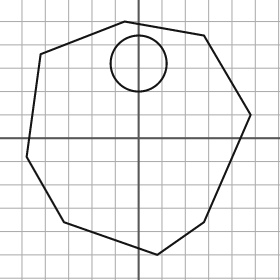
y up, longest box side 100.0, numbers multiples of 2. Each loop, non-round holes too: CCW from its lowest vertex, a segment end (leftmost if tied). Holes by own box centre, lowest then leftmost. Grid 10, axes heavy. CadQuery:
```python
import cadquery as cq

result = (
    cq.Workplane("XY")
    .moveTo(8.0, -50.0)
    .lineTo(28.0, -36.0)
    .lineTo(48.0, 10.0)
    .lineTo(28.0, 44.0)
    .lineTo(-6.0, 50.0)
    .lineTo(-42.0, 36.0)
    .lineTo(-48.0, -8.0)
    .lineTo(-32.0, -36.0)
    .close()
    .moveTo(0.0, 32.0)
    .circle(12.0)
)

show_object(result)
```